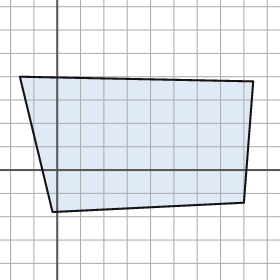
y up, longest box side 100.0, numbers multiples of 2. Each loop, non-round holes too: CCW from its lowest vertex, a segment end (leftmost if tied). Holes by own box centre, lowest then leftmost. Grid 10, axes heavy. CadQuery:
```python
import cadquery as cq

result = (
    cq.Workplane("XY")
    .moveTo(-2.0, -18.0)
    .lineTo(80.0, -14.0)
    .lineTo(84.0, 38.0)
    .lineTo(-16.0, 40.0)
    .close()
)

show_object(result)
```